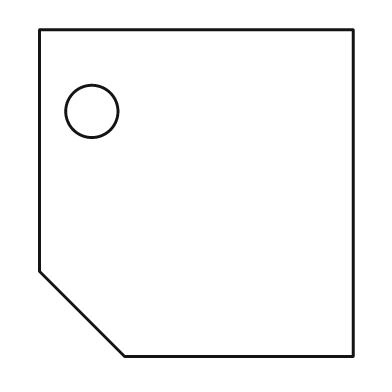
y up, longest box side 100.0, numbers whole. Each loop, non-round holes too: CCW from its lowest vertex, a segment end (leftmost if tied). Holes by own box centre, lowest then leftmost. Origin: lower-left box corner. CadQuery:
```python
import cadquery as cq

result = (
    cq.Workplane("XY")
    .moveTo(26.0, 0.0)
    .lineTo(96.0, 0.0)
    .lineTo(96.0, 100.0)
    .lineTo(0.0, 100.0)
    .lineTo(0.0, 26.0)
    .close()
    .moveTo(16.0, 75.0)
    .circle(8.0)
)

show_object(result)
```